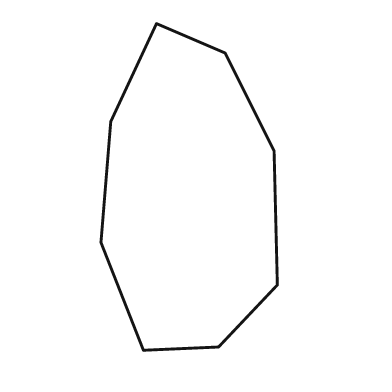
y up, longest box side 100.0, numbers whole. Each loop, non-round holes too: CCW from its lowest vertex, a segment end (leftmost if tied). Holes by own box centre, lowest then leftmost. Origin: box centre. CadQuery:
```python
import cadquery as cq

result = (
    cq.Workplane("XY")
    .moveTo(-14.0, -50.0)
    .lineTo(9.0, -49.0)
    .lineTo(27.0, -30.0)
    .lineTo(26.0, 11.0)
    .lineTo(11.0, 41.0)
    .lineTo(-10.0, 50.0)
    .lineTo(-24.0, 20.0)
    .lineTo(-27.0, -17.0)
    .close()
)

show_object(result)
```